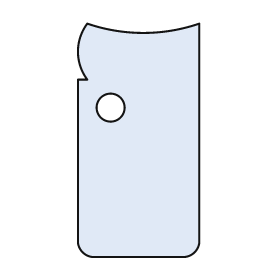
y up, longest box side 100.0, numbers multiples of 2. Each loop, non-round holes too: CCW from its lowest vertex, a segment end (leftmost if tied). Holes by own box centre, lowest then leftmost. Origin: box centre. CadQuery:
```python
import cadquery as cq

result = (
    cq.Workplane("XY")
    .moveTo(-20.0, -50.0)
    .lineTo(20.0, -50.0)
    .threePointArc((24.0, -48.0), (26.0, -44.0))
    .lineTo(26.0, 50.0)
    .threePointArc((2.0, 46.0), (-22.0, 50.0))
    .threePointArc((-26.0, 38.0), (-22.0, 26.0))
    .lineTo(-26.0, 26.0)
    .lineTo(-26.0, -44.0)
    .threePointArc((-24.0, -48.0), (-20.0, -50.0))
    .close()
    .moveTo(-12.0, 14.0)
    .circle(6.0)
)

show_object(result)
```